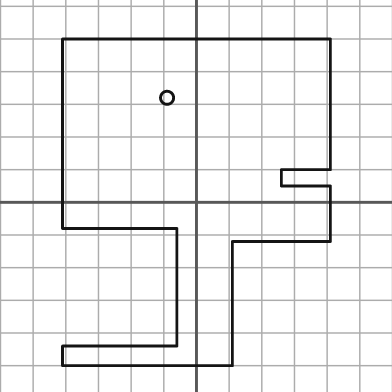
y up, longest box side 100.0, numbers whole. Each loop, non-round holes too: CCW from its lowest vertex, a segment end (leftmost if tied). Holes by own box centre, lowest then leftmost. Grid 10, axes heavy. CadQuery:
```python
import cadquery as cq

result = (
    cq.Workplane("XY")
    .moveTo(-41.0, -50.0)
    .lineTo(11.0, -50.0)
    .lineTo(11.0, -12.0)
    .lineTo(41.0, -12.0)
    .lineTo(41.0, 5.0)
    .lineTo(26.0, 5.0)
    .lineTo(26.0, 10.0)
    .lineTo(41.0, 10.0)
    .lineTo(41.0, 50.0)
    .lineTo(-41.0, 50.0)
    .lineTo(-41.0, -8.0)
    .lineTo(-6.0, -8.0)
    .lineTo(-6.0, -44.0)
    .lineTo(-41.0, -44.0)
    .close()
    .moveTo(-9.0, 32.0)
    .circle(2.0)
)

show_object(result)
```